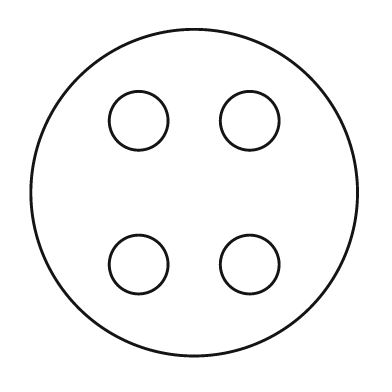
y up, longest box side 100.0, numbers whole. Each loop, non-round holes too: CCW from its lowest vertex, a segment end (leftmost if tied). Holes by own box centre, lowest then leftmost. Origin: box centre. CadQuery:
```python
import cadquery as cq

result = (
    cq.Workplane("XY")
    .moveTo(0.0, 0.0)
    .circle(50.0)
    .moveTo(-17.0, -22.0)
    .circle(9.0)
    .moveTo(17.0, -22.0)
    .circle(9.0)
    .moveTo(-17.0, 22.0)
    .circle(9.0)
    .moveTo(17.0, 22.0)
    .circle(9.0)
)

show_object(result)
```